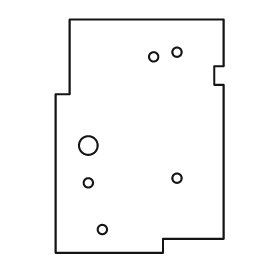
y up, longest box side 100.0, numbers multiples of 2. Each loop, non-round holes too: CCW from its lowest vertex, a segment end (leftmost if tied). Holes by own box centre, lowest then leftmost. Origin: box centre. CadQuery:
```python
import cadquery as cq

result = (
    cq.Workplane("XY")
    .moveTo(-36.0, -50.0)
    .lineTo(10.0, -50.0)
    .lineTo(10.0, -44.0)
    .lineTo(36.0, -44.0)
    .lineTo(36.0, 22.0)
    .lineTo(32.0, 22.0)
    .lineTo(32.0, 30.0)
    .lineTo(36.0, 30.0)
    .lineTo(36.0, 50.0)
    .lineTo(-30.0, 50.0)
    .lineTo(-30.0, 18.0)
    .lineTo(-36.0, 18.0)
    .close()
    .moveTo(-16.0, -40.0)
    .circle(2.0)
    .moveTo(-22.0, -20.0)
    .circle(2.0)
    .moveTo(16.0, -18.0)
    .circle(2.0)
    .moveTo(-22.0, -4.0)
    .circle(4.0)
    .moveTo(6.0, 34.0)
    .circle(2.0)
    .moveTo(16.0, 36.0)
    .circle(2.0)
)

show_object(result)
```